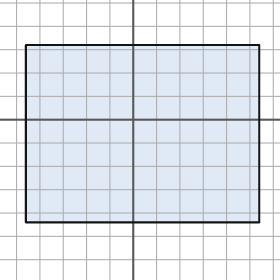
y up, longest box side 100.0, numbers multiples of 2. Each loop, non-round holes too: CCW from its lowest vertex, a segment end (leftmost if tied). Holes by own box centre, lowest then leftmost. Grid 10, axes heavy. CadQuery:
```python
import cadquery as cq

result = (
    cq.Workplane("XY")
    .moveTo(-46.0, -44.0)
    .lineTo(54.0, -44.0)
    .lineTo(54.0, 32.0)
    .lineTo(-46.0, 32.0)
    .close()
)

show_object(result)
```